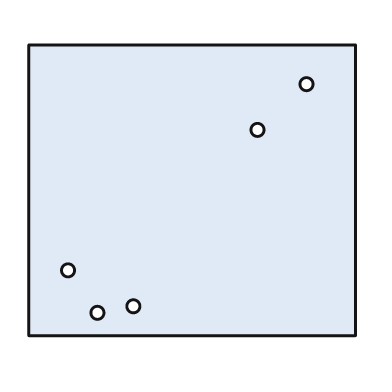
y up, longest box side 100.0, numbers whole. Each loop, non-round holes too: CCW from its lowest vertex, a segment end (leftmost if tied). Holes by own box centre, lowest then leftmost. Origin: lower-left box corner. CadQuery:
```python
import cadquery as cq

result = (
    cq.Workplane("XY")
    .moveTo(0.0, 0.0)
    .lineTo(100.0, 0.0)
    .lineTo(100.0, 89.0)
    .lineTo(0.0, 89.0)
    .close()
    .moveTo(21.0, 7.0)
    .circle(2.0)
    .moveTo(32.0, 9.0)
    .circle(2.0)
    .moveTo(12.0, 20.0)
    .circle(2.0)
    .moveTo(70.0, 63.0)
    .circle(2.0)
    .moveTo(85.0, 77.0)
    .circle(2.0)
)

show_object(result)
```